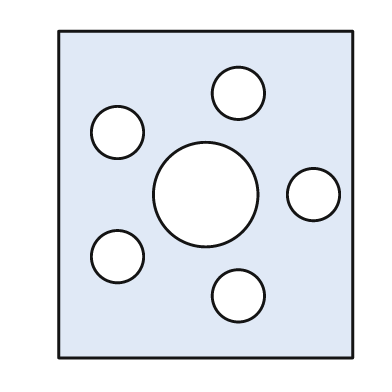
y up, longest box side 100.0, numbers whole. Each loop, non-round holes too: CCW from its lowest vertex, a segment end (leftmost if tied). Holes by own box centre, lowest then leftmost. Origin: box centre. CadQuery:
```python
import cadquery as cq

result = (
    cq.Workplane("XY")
    .moveTo(-45.0, -50.0)
    .lineTo(45.0, -50.0)
    .lineTo(45.0, 50.0)
    .lineTo(-45.0, 50.0)
    .close()
    .moveTo(10.0, -31.0)
    .circle(8.0)
    .moveTo(-27.0, -19.0)
    .circle(8.0)
    .moveTo(0.0, 0.0)
    .circle(16.0)
    .moveTo(33.0, 0.0)
    .circle(8.0)
    .moveTo(-27.0, 19.0)
    .circle(8.0)
    .moveTo(10.0, 31.0)
    .circle(8.0)
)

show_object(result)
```